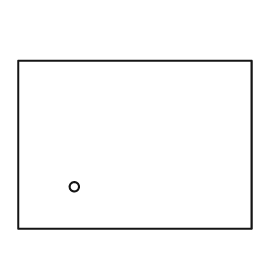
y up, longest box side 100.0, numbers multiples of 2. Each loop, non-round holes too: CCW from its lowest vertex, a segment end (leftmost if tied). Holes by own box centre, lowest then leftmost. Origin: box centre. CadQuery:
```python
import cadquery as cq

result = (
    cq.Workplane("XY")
    .moveTo(-50.0, -36.0)
    .lineTo(50.0, -36.0)
    .lineTo(50.0, 36.0)
    .lineTo(-50.0, 36.0)
    .close()
    .moveTo(-26.0, -18.0)
    .circle(2.0)
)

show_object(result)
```